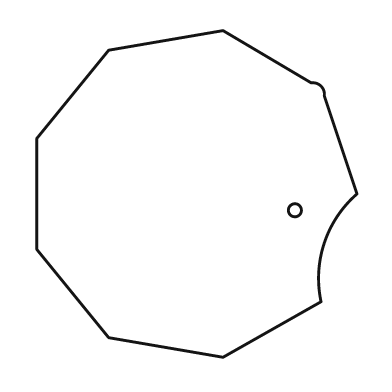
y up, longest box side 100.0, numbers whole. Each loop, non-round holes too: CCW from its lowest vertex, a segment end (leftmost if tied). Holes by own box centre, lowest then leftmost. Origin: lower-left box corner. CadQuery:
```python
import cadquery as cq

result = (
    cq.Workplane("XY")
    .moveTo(57.0, 0.0)
    .lineTo(87.0, 17.0)
    .threePointArc((88.0, 35.0), (98.0, 50.0))
    .lineTo(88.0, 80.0)
    .threePointArc((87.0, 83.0), (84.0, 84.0))
    .lineTo(57.0, 100.0)
    .lineTo(22.0, 94.0)
    .lineTo(0.0, 67.0)
    .lineTo(0.0, 33.0)
    .lineTo(22.0, 6.0)
    .close()
    .moveTo(79.0, 45.0)
    .circle(2.0)
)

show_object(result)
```